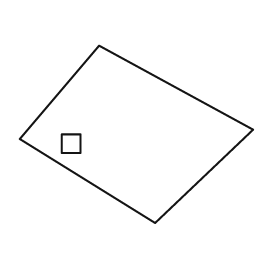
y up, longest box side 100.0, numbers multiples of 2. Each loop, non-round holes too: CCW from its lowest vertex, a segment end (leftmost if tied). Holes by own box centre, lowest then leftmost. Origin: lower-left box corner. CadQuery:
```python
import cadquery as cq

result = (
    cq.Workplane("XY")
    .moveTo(58.0, 0.0)
    .lineTo(100.0, 40.0)
    .lineTo(34.0, 76.0)
    .lineTo(0.0, 36.0)
    .close()
    .moveTo(18.0, 30.0)
    .lineTo(26.0, 30.0)
    .lineTo(26.0, 38.0)
    .lineTo(18.0, 38.0)
    .close()
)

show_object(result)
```